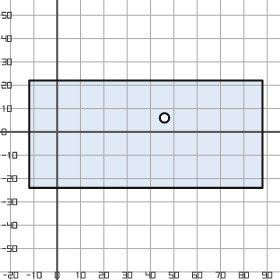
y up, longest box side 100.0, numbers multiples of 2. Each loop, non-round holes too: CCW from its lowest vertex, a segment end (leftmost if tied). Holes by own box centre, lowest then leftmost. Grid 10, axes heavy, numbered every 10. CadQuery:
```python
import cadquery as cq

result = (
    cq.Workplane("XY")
    .moveTo(-12.0, -24.0)
    .lineTo(88.0, -24.0)
    .lineTo(88.0, 22.0)
    .lineTo(-12.0, 22.0)
    .close()
    .moveTo(46.0, 6.0)
    .circle(2.0)
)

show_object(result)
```